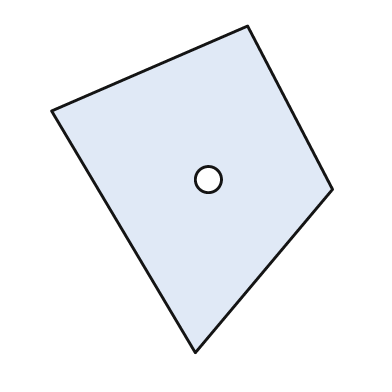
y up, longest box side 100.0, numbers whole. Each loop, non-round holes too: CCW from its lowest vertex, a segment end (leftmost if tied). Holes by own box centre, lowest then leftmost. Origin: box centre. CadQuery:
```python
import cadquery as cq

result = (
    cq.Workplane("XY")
    .moveTo(1.0, -50.0)
    .lineTo(43.0, 0.0)
    .lineTo(17.0, 50.0)
    .lineTo(-43.0, 24.0)
    .close()
    .moveTo(5.0, 3.0)
    .circle(4.0)
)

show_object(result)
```